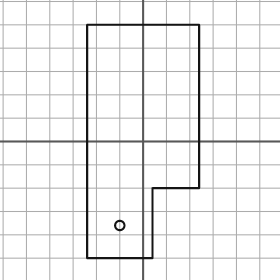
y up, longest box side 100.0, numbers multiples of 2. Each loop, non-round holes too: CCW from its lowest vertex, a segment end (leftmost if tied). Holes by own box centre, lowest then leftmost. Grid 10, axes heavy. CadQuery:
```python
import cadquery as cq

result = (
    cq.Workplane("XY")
    .moveTo(-24.0, -50.0)
    .lineTo(4.0, -50.0)
    .lineTo(4.0, -20.0)
    .lineTo(24.0, -20.0)
    .lineTo(24.0, 50.0)
    .lineTo(-24.0, 50.0)
    .close()
    .moveTo(-10.0, -36.0)
    .circle(2.0)
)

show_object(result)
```